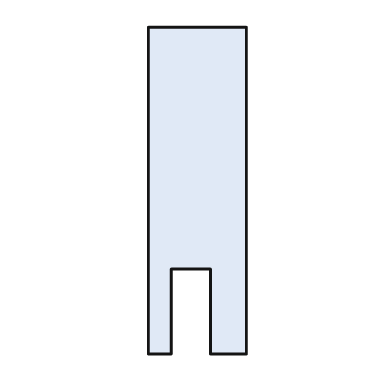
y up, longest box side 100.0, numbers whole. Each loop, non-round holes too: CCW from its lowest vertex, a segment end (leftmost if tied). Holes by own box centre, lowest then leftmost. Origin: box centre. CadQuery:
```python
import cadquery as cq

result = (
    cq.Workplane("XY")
    .moveTo(-15.0, -50.0)
    .lineTo(-8.0, -50.0)
    .lineTo(-8.0, -24.0)
    .lineTo(4.0, -24.0)
    .lineTo(4.0, -50.0)
    .lineTo(15.0, -50.0)
    .lineTo(15.0, 50.0)
    .lineTo(-15.0, 50.0)
    .close()
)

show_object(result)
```